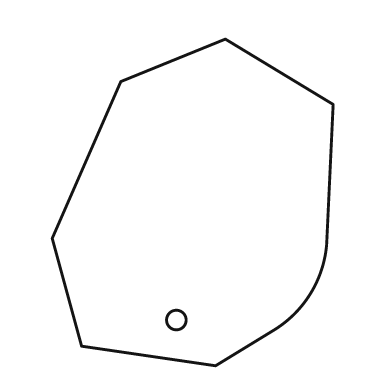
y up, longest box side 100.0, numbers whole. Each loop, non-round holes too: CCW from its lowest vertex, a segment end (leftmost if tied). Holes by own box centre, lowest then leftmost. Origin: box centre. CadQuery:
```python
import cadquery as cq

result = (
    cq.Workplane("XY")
    .moveTo(7.0, -50.0)
    .lineTo(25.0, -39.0)
    .threePointArc((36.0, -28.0), (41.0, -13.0))
    .lineTo(43.0, 30.0)
    .lineTo(10.0, 50.0)
    .lineTo(-22.0, 37.0)
    .lineTo(-43.0, -11.0)
    .lineTo(-34.0, -44.0)
    .close()
    .moveTo(-5.0, -36.0)
    .circle(3.0)
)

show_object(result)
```